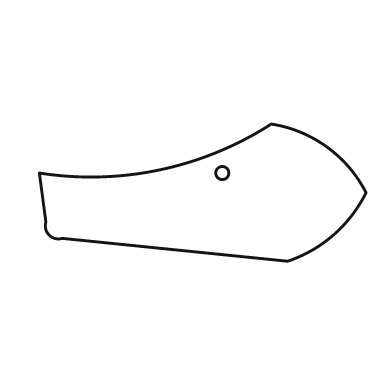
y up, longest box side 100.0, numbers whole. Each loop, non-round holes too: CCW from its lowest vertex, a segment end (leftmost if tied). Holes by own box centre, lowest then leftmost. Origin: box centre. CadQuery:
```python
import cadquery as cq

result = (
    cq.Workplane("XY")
    .moveTo(26.0, -21.0)
    .threePointArc((40.0, -13.0), (50.0, 0.0))
    .threePointArc((38.0, 14.0), (21.0, 21.0))
    .threePointArc((-13.0, 7.0), (-50.0, 6.0))
    .lineTo(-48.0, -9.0)
    .threePointArc((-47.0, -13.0), (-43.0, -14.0))
    .close()
    .moveTo(6.0, 6.0)
    .circle(2.0)
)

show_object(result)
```